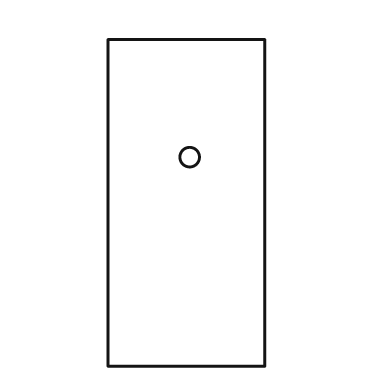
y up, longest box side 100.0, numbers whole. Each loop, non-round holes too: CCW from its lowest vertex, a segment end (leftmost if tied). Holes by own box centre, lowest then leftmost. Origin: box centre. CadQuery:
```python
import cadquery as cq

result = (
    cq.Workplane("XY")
    .moveTo(-24.0, -50.0)
    .lineTo(24.0, -50.0)
    .lineTo(24.0, 50.0)
    .lineTo(-24.0, 50.0)
    .close()
    .moveTo(1.0, 14.0)
    .circle(3.0)
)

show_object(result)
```